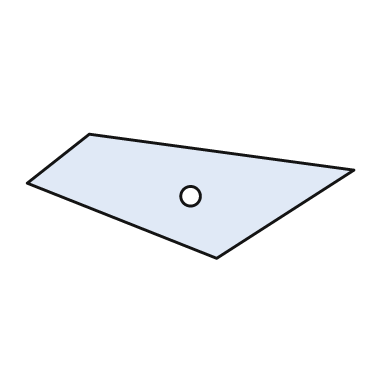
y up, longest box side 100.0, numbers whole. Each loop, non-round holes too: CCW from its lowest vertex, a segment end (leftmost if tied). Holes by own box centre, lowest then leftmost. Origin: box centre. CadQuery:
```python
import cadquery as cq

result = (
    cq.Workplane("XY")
    .moveTo(8.0, -19.0)
    .lineTo(50.0, 8.0)
    .lineTo(-31.0, 19.0)
    .lineTo(-50.0, 4.0)
    .close()
    .moveTo(0.0, 0.0)
    .circle(3.0)
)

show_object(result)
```